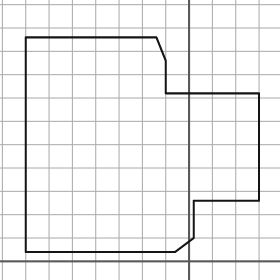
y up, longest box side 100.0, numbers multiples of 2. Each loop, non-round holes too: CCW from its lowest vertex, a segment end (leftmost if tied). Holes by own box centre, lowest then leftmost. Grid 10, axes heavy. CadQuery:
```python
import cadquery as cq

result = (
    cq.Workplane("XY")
    .moveTo(-70.0, 4.0)
    .lineTo(-6.0, 4.0)
    .lineTo(2.0, 10.0)
    .lineTo(2.0, 26.0)
    .lineTo(30.0, 26.0)
    .lineTo(30.0, 72.0)
    .lineTo(-10.0, 72.0)
    .lineTo(-10.0, 86.0)
    .lineTo(-14.0, 96.0)
    .lineTo(-70.0, 96.0)
    .close()
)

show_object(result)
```